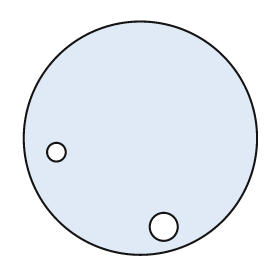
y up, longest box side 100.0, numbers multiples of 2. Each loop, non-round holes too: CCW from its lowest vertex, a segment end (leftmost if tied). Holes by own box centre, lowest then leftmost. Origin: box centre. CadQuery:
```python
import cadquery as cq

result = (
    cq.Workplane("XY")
    .moveTo(0.0, 0.0)
    .circle(50.0)
    .moveTo(10.0, -38.0)
    .circle(6.0)
    .moveTo(-36.0, -6.0)
    .circle(4.0)
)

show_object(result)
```